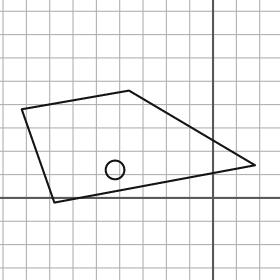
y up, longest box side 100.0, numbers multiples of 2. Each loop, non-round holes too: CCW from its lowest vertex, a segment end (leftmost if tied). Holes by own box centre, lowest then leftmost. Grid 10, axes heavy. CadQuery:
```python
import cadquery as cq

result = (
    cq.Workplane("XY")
    .moveTo(-68.0, -2.0)
    .lineTo(18.0, 14.0)
    .lineTo(-36.0, 46.0)
    .lineTo(-82.0, 38.0)
    .close()
    .moveTo(-42.0, 12.0)
    .circle(4.0)
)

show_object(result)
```